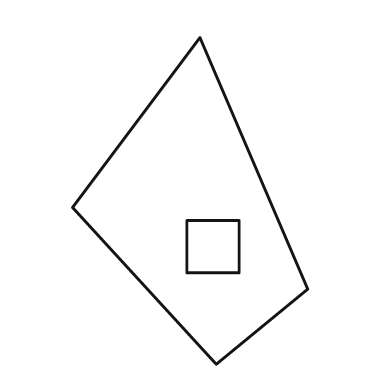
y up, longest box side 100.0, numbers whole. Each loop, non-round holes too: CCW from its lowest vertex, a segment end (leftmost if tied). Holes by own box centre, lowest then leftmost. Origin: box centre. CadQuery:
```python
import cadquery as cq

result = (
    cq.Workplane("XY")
    .moveTo(8.0, -50.0)
    .lineTo(36.0, -27.0)
    .lineTo(3.0, 50.0)
    .lineTo(-36.0, -2.0)
    .close()
    .moveTo(-1.0, -22.0)
    .lineTo(15.0, -22.0)
    .lineTo(15.0, -6.0)
    .lineTo(-1.0, -6.0)
    .close()
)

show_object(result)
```